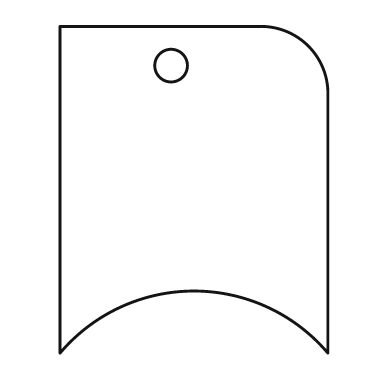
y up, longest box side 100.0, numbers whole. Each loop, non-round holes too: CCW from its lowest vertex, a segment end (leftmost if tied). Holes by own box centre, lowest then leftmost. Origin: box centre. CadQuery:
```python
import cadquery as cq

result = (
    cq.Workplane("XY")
    .moveTo(-41.0, -50.0)
    .threePointArc((0.0, -31.0), (41.0, -50.0))
    .lineTo(41.0, 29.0)
    .threePointArc((35.0, 44.0), (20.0, 50.0))
    .lineTo(-41.0, 50.0)
    .close()
    .moveTo(-7.0, 38.0)
    .circle(5.0)
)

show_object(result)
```